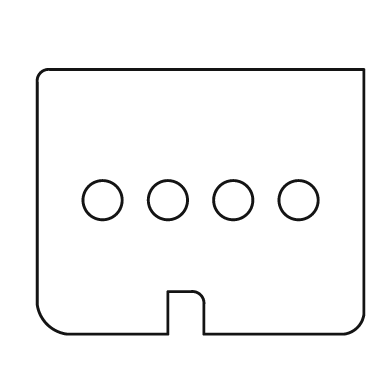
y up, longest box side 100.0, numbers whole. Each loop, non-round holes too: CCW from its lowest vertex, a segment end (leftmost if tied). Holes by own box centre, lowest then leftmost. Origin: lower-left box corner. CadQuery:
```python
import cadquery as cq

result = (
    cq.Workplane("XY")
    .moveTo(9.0, 0.0)
    .lineTo(40.0, 0.0)
    .lineTo(40.0, 13.0)
    .lineTo(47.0, 13.0)
    .threePointArc((50.0, 12.0), (51.0, 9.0))
    .lineTo(51.0, 0.0)
    .lineTo(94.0, 0.0)
    .threePointArc((98.0, 2.0), (100.0, 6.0))
    .lineTo(100.0, 81.0)
    .lineTo(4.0, 81.0)
    .threePointArc((1.0, 80.0), (0.0, 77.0))
    .lineTo(0.0, 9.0)
    .threePointArc((3.0, 3.0), (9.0, 0.0))
    .close()
    .moveTo(20.0, 41.0)
    .circle(6.0)
    .moveTo(40.0, 41.0)
    .circle(6.0)
    .moveTo(60.0, 41.0)
    .circle(6.0)
    .moveTo(80.0, 41.0)
    .circle(6.0)
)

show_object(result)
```